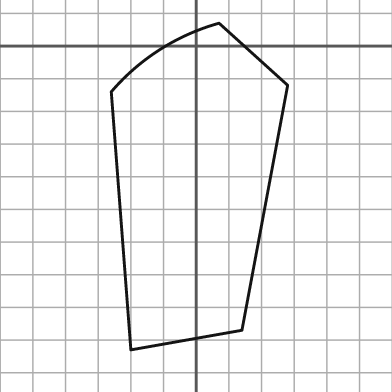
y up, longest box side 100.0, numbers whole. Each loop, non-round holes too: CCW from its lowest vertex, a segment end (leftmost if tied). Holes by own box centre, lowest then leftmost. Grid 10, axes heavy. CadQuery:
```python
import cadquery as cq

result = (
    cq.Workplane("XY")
    .moveTo(-20.0, -93.0)
    .lineTo(14.0, -87.0)
    .lineTo(28.0, -12.0)
    .lineTo(7.0, 7.0)
    .threePointArc((-11.0, -1.0), (-26.0, -14.0))
    .close()
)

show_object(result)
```